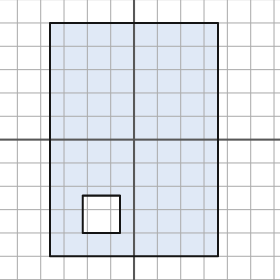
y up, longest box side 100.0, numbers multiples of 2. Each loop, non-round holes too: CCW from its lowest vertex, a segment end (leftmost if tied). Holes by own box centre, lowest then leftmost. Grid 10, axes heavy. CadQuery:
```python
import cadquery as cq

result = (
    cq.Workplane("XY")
    .moveTo(-36.0, -50.0)
    .lineTo(36.0, -50.0)
    .lineTo(36.0, 50.0)
    .lineTo(-36.0, 50.0)
    .close()
    .moveTo(-22.0, -40.0)
    .lineTo(-6.0, -40.0)
    .lineTo(-6.0, -24.0)
    .lineTo(-22.0, -24.0)
    .close()
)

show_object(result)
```